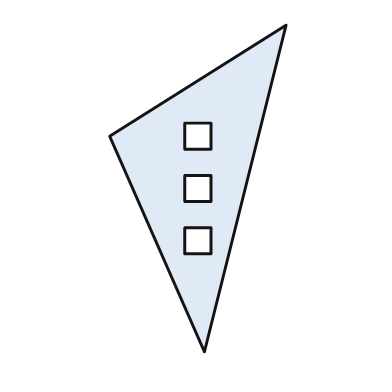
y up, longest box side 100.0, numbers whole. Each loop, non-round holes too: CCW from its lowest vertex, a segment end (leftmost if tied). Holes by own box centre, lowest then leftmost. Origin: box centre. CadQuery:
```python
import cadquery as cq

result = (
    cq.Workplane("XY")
    .moveTo(2.0, -50.0)
    .lineTo(27.0, 50.0)
    .lineTo(-27.0, 16.0)
    .close()
    .moveTo(-4.0, -20.0)
    .lineTo(4.0, -20.0)
    .lineTo(4.0, -12.0)
    .lineTo(-4.0, -12.0)
    .close()
    .moveTo(-4.0, -4.0)
    .lineTo(4.0, -4.0)
    .lineTo(4.0, 4.0)
    .lineTo(-4.0, 4.0)
    .close()
    .moveTo(-4.0, 12.0)
    .lineTo(4.0, 12.0)
    .lineTo(4.0, 20.0)
    .lineTo(-4.0, 20.0)
    .close()
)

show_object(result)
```